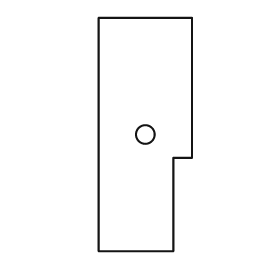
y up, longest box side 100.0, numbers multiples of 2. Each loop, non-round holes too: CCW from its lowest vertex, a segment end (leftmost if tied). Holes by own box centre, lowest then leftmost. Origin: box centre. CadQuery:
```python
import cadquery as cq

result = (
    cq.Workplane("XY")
    .moveTo(-20.0, -50.0)
    .lineTo(12.0, -50.0)
    .lineTo(12.0, -10.0)
    .lineTo(20.0, -10.0)
    .lineTo(20.0, 50.0)
    .lineTo(-20.0, 50.0)
    .close()
    .moveTo(0.0, 0.0)
    .circle(4.0)
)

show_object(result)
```